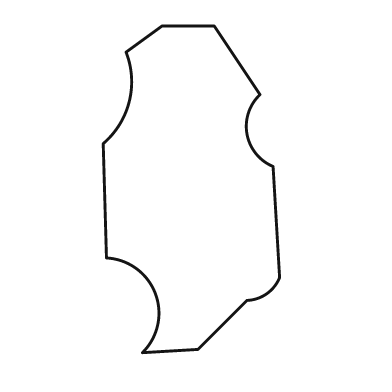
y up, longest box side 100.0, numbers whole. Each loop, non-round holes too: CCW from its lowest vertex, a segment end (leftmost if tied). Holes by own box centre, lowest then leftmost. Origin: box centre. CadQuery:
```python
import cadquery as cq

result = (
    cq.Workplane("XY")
    .moveTo(-15.0, -50.0)
    .lineTo(2.0, -49.0)
    .lineTo(17.0, -34.0)
    .threePointArc((23.0, -32.0), (27.0, -27.0))
    .lineTo(25.0, 7.0)
    .threePointArc((17.0, 17.0), (21.0, 29.0))
    .lineTo(7.0, 50.0)
    .lineTo(-9.0, 50.0)
    .lineTo(-20.0, 42.0)
    .threePointArc((-19.0, 27.0), (-27.0, 14.0))
    .lineTo(-26.0, -21.0)
    .threePointArc((-11.0, -32.0), (-15.0, -50.0))
    .close()
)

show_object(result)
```